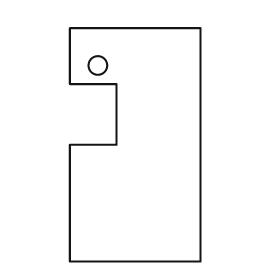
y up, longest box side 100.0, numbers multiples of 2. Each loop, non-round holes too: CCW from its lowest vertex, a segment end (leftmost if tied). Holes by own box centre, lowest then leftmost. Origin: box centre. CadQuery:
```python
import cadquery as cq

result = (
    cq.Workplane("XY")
    .moveTo(-28.0, -50.0)
    .lineTo(28.0, -50.0)
    .lineTo(28.0, 50.0)
    .lineTo(-28.0, 50.0)
    .lineTo(-28.0, 26.0)
    .lineTo(-8.0, 26.0)
    .lineTo(-8.0, 0.0)
    .lineTo(-28.0, 0.0)
    .close()
    .moveTo(-16.0, 34.0)
    .circle(4.0)
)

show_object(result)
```